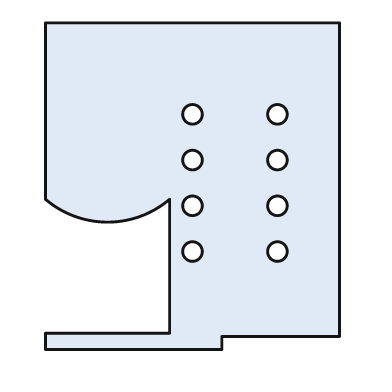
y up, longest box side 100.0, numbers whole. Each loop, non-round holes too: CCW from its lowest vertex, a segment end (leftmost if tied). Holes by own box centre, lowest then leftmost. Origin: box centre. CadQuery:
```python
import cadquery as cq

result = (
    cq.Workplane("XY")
    .moveTo(-45.0, -50.0)
    .lineTo(9.0, -50.0)
    .lineTo(9.0, -46.0)
    .lineTo(45.0, -46.0)
    .lineTo(45.0, 50.0)
    .lineTo(-45.0, 50.0)
    .lineTo(-45.0, -4.0)
    .threePointArc((-26.0, -11.0), (-7.0, -4.0))
    .lineTo(-7.0, -45.0)
    .lineTo(-45.0, -45.0)
    .close()
    .moveTo(0.0, -20.0)
    .circle(3.0)
    .moveTo(26.0, -20.0)
    .circle(3.0)
    .moveTo(0.0, -6.0)
    .circle(3.0)
    .moveTo(26.0, -6.0)
    .circle(3.0)
    .moveTo(0.0, 8.0)
    .circle(3.0)
    .moveTo(26.0, 8.0)
    .circle(3.0)
    .moveTo(0.0, 22.0)
    .circle(3.0)
    .moveTo(26.0, 22.0)
    .circle(3.0)
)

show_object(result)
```